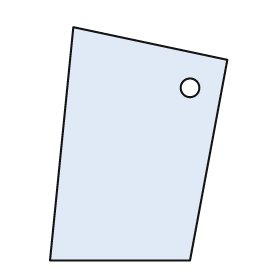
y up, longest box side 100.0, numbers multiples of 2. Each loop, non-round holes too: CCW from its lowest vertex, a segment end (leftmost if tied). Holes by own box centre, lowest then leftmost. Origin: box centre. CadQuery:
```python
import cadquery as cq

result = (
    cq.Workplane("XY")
    .moveTo(-38.0, -50.0)
    .lineTo(22.0, -50.0)
    .lineTo(38.0, 36.0)
    .lineTo(-28.0, 50.0)
    .close()
    .moveTo(22.0, 24.0)
    .circle(4.0)
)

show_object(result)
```